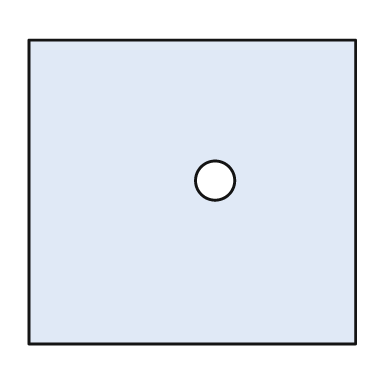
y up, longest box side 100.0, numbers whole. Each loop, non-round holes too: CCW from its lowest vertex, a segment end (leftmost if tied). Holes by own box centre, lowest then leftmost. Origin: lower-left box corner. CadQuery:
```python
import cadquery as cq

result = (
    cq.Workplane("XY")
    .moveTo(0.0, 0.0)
    .lineTo(100.0, 0.0)
    .lineTo(100.0, 93.0)
    .lineTo(0.0, 93.0)
    .close()
    .moveTo(57.0, 50.0)
    .circle(6.0)
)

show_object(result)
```